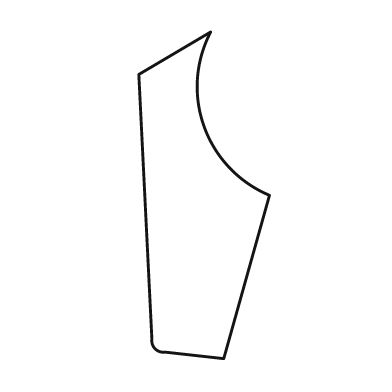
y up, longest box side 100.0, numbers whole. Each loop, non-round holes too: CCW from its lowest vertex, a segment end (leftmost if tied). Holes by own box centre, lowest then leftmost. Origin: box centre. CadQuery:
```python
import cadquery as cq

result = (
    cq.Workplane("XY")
    .moveTo(6.0, -50.0)
    .lineTo(20.0, 0.0)
    .threePointArc((0.0, 21.0), (2.0, 50.0))
    .lineTo(-20.0, 37.0)
    .lineTo(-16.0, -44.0)
    .threePointArc((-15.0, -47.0), (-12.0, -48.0))
    .close()
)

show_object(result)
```